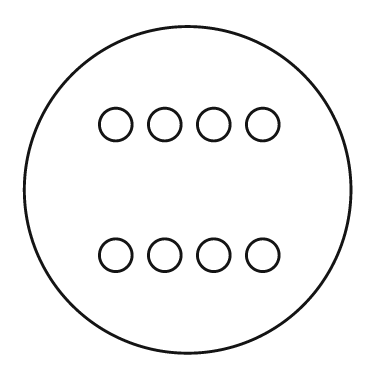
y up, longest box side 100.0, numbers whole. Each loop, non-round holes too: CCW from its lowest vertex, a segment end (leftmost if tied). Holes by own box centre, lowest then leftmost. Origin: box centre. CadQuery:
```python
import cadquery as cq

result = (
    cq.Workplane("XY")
    .moveTo(0.0, 0.0)
    .circle(50.0)
    .moveTo(-22.0, -20.0)
    .circle(5.0)
    .moveTo(-7.0, -20.0)
    .circle(5.0)
    .moveTo(8.0, -20.0)
    .circle(5.0)
    .moveTo(23.0, -20.0)
    .circle(5.0)
    .moveTo(-22.0, 20.0)
    .circle(5.0)
    .moveTo(-7.0, 20.0)
    .circle(5.0)
    .moveTo(8.0, 20.0)
    .circle(5.0)
    .moveTo(23.0, 20.0)
    .circle(5.0)
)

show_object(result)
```